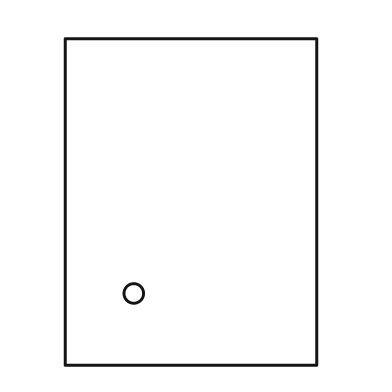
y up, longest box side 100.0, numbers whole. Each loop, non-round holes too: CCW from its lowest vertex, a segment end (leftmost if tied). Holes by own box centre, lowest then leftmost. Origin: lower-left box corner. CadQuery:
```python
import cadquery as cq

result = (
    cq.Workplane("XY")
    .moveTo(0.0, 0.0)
    .lineTo(77.0, 0.0)
    .lineTo(77.0, 100.0)
    .lineTo(0.0, 100.0)
    .close()
    .moveTo(21.0, 22.0)
    .circle(3.0)
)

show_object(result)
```